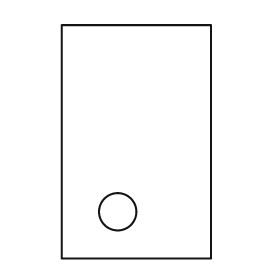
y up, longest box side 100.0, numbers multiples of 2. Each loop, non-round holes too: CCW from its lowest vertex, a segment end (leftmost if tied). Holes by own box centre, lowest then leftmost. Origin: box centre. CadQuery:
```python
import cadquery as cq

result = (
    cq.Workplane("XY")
    .moveTo(-32.0, -50.0)
    .lineTo(32.0, -50.0)
    .lineTo(32.0, 50.0)
    .lineTo(-32.0, 50.0)
    .close()
    .moveTo(-8.0, -30.0)
    .circle(8.0)
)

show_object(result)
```